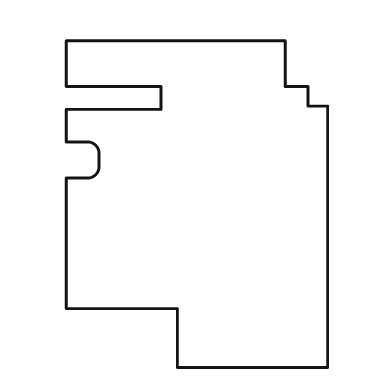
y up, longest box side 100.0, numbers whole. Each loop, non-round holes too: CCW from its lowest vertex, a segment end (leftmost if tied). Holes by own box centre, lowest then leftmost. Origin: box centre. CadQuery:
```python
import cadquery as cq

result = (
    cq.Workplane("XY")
    .moveTo(-6.0, -50.0)
    .lineTo(40.0, -50.0)
    .lineTo(40.0, 30.0)
    .lineTo(34.0, 30.0)
    .lineTo(34.0, 36.0)
    .lineTo(27.0, 36.0)
    .lineTo(27.0, 50.0)
    .lineTo(-40.0, 50.0)
    .lineTo(-40.0, 36.0)
    .lineTo(-11.0, 36.0)
    .lineTo(-11.0, 29.0)
    .lineTo(-40.0, 29.0)
    .lineTo(-40.0, 19.0)
    .lineTo(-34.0, 19.0)
    .threePointArc((-31.0, 18.0), (-30.0, 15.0))
    .lineTo(-30.0, 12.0)
    .threePointArc((-31.0, 9.0), (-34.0, 8.0))
    .lineTo(-40.0, 8.0)
    .lineTo(-40.0, -32.0)
    .lineTo(-6.0, -32.0)
    .close()
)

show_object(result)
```